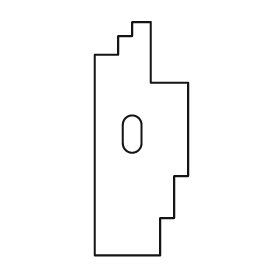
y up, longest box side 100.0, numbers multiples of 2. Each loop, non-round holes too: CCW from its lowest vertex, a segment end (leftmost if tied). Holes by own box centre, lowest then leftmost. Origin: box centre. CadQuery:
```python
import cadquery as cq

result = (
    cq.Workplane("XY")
    .moveTo(-20.0, -50.0)
    .lineTo(8.0, -50.0)
    .lineTo(8.0, -34.0)
    .lineTo(14.0, -34.0)
    .lineTo(14.0, -16.0)
    .lineTo(20.0, -16.0)
    .lineTo(20.0, 24.0)
    .lineTo(4.0, 24.0)
    .lineTo(4.0, 50.0)
    .lineTo(-4.0, 50.0)
    .lineTo(-4.0, 44.0)
    .lineTo(-10.0, 44.0)
    .lineTo(-10.0, 36.0)
    .lineTo(-20.0, 36.0)
    .close()
    .moveTo(-8.0, -2.0)
    .threePointArc((-4.0, -6.0), (0.0, -2.0))
    .lineTo(0.0, 6.0)
    .threePointArc((-4.0, 10.0), (-8.0, 6.0))
    .close()
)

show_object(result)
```